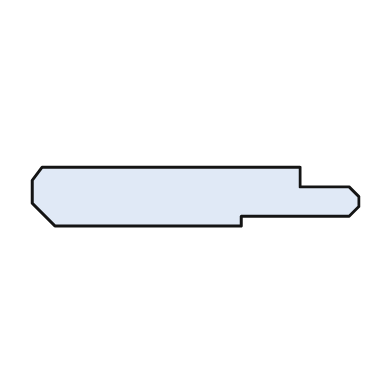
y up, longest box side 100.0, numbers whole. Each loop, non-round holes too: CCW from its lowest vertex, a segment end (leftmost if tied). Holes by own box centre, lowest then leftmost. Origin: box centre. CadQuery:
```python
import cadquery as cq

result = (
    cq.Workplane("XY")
    .moveTo(-43.0, -9.0)
    .lineTo(14.0, -9.0)
    .lineTo(14.0, -6.0)
    .lineTo(47.0, -6.0)
    .lineTo(50.0, -3.0)
    .lineTo(50.0, 0.0)
    .lineTo(47.0, 3.0)
    .lineTo(32.0, 3.0)
    .lineTo(32.0, 9.0)
    .lineTo(-47.0, 9.0)
    .lineTo(-50.0, 5.0)
    .lineTo(-50.0, -2.0)
    .close()
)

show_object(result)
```